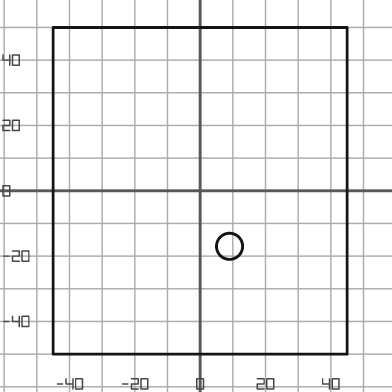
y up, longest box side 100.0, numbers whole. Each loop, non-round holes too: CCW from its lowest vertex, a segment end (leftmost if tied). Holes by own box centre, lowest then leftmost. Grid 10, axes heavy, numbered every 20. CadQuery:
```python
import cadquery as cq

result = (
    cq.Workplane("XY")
    .moveTo(-45.0, -50.0)
    .lineTo(45.0, -50.0)
    .lineTo(45.0, 50.0)
    .lineTo(-45.0, 50.0)
    .close()
    .moveTo(9.0, -17.0)
    .circle(4.0)
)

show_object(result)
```